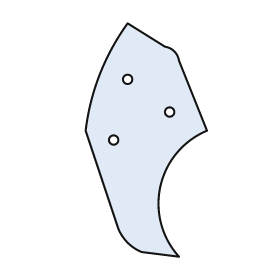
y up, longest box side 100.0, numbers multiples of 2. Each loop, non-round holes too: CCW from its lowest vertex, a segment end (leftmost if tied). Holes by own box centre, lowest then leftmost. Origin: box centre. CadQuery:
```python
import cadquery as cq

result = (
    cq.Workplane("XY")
    .moveTo(14.0, -50.0)
    .threePointArc((6.0, -20.0), (26.0, 4.0))
    .lineTo(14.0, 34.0)
    .threePointArc((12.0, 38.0), (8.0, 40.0))
    .lineTo(-8.0, 50.0)
    .threePointArc((-20.0, 28.0), (-26.0, 4.0))
    .lineTo(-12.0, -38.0)
    .threePointArc((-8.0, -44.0), (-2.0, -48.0))
    .close()
    .moveTo(-14.0, 0.0)
    .circle(2.0)
    .moveTo(10.0, 12.0)
    .circle(2.0)
    .moveTo(-8.0, 26.0)
    .circle(2.0)
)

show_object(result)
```